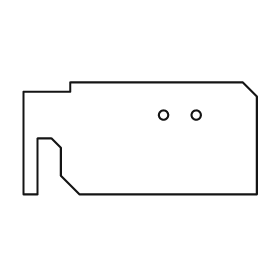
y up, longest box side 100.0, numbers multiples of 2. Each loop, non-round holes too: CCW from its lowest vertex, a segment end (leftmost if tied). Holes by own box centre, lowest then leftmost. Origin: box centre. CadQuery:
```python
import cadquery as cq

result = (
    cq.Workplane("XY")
    .moveTo(-50.0, -24.0)
    .lineTo(-44.0, -24.0)
    .lineTo(-44.0, 0.0)
    .lineTo(-38.0, 0.0)
    .lineTo(-34.0, -4.0)
    .lineTo(-34.0, -16.0)
    .lineTo(-26.0, -24.0)
    .lineTo(50.0, -24.0)
    .lineTo(50.0, 18.0)
    .lineTo(44.0, 24.0)
    .lineTo(-30.0, 24.0)
    .lineTo(-30.0, 20.0)
    .lineTo(-50.0, 20.0)
    .close()
    .moveTo(10.0, 10.0)
    .circle(2.0)
    .moveTo(24.0, 10.0)
    .circle(2.0)
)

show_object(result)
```